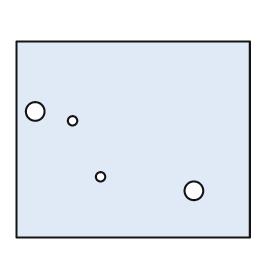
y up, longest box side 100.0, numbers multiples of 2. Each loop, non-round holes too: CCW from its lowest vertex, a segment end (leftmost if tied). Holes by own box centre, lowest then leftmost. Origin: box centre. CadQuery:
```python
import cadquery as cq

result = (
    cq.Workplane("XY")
    .moveTo(-50.0, -42.0)
    .lineTo(50.0, -42.0)
    .lineTo(50.0, 42.0)
    .lineTo(-50.0, 42.0)
    .close()
    .moveTo(26.0, -22.0)
    .circle(4.0)
    .moveTo(-14.0, -16.0)
    .circle(2.0)
    .moveTo(-26.0, 8.0)
    .circle(2.0)
    .moveTo(-42.0, 12.0)
    .circle(4.0)
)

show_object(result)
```